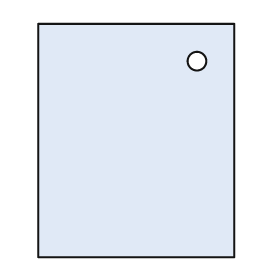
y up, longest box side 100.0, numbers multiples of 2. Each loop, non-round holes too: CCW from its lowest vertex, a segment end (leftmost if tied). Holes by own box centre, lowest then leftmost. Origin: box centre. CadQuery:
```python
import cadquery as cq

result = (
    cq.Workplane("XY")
    .moveTo(-42.0, -50.0)
    .lineTo(42.0, -50.0)
    .lineTo(42.0, 50.0)
    .lineTo(-42.0, 50.0)
    .close()
    .moveTo(26.0, 34.0)
    .circle(4.0)
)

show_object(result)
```